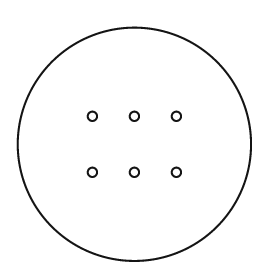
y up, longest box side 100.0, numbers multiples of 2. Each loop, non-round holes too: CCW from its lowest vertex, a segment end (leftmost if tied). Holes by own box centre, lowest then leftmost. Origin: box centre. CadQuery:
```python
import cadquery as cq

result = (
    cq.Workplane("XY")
    .moveTo(0.0, 0.0)
    .circle(50.0)
    .moveTo(-18.0, -12.0)
    .circle(2.0)
    .moveTo(0.0, -12.0)
    .circle(2.0)
    .moveTo(18.0, -12.0)
    .circle(2.0)
    .moveTo(-18.0, 12.0)
    .circle(2.0)
    .moveTo(0.0, 12.0)
    .circle(2.0)
    .moveTo(18.0, 12.0)
    .circle(2.0)
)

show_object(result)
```